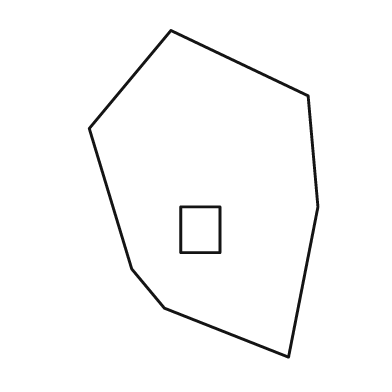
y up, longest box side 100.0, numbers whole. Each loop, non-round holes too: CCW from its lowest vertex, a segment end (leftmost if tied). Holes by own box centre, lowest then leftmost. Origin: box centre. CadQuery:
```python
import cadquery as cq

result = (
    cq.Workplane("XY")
    .moveTo(26.0, -50.0)
    .lineTo(35.0, -4.0)
    .lineTo(32.0, 30.0)
    .lineTo(-10.0, 50.0)
    .lineTo(-35.0, 20.0)
    .lineTo(-22.0, -23.0)
    .lineTo(-12.0, -35.0)
    .close()
    .moveTo(-7.0, -18.0)
    .lineTo(5.0, -18.0)
    .lineTo(5.0, -4.0)
    .lineTo(-7.0, -4.0)
    .close()
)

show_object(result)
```